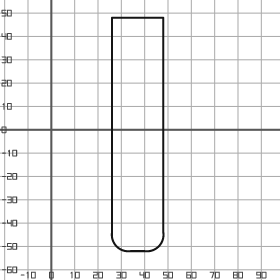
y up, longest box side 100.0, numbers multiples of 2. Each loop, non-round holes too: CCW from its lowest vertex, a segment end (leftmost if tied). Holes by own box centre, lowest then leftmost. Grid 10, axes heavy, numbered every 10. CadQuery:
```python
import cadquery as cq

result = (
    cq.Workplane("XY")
    .moveTo(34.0, -52.0)
    .lineTo(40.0, -52.0)
    .threePointArc((46.0, -50.0), (48.0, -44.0))
    .lineTo(48.0, 48.0)
    .lineTo(26.0, 48.0)
    .lineTo(26.0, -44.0)
    .threePointArc((28.0, -50.0), (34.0, -52.0))
    .close()
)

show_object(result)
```